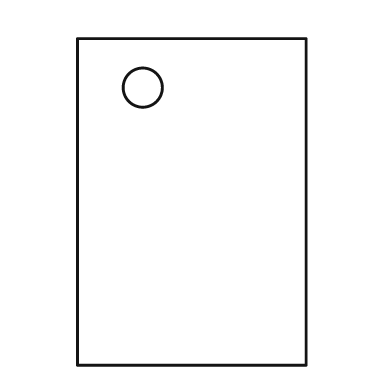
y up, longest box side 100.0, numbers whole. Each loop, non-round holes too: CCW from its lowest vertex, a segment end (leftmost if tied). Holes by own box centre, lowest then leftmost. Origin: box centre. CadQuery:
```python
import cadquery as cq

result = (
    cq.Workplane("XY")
    .moveTo(-35.0, -50.0)
    .lineTo(35.0, -50.0)
    .lineTo(35.0, 50.0)
    .lineTo(-35.0, 50.0)
    .close()
    .moveTo(-15.0, 35.0)
    .circle(6.0)
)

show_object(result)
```